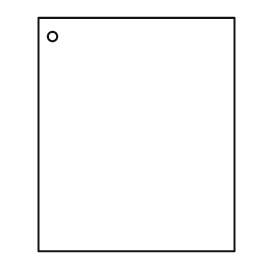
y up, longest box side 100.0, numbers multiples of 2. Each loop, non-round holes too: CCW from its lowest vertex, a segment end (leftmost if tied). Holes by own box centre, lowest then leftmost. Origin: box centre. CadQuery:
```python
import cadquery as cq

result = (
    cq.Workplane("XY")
    .moveTo(-42.0, -50.0)
    .lineTo(42.0, -50.0)
    .lineTo(42.0, 50.0)
    .lineTo(-42.0, 50.0)
    .close()
    .moveTo(-36.0, 42.0)
    .circle(2.0)
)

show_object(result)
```